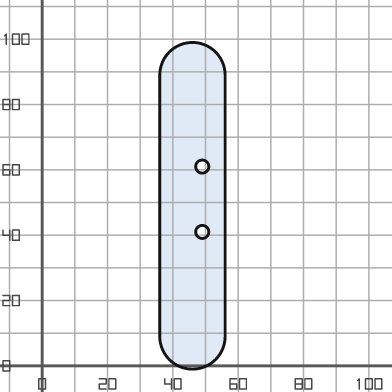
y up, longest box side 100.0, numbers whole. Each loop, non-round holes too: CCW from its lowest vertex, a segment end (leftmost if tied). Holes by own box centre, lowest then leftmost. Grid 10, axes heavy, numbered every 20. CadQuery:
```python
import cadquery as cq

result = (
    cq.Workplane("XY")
    .moveTo(36.0, 9.0)
    .threePointArc((46.0, -1.0), (56.0, 9.0))
    .lineTo(56.0, 89.0)
    .threePointArc((46.0, 99.0), (36.0, 89.0))
    .close()
    .moveTo(49.0, 41.0)
    .circle(2.0)
    .moveTo(49.0, 61.0)
    .circle(2.0)
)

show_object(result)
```